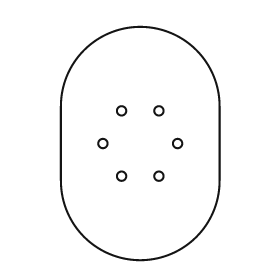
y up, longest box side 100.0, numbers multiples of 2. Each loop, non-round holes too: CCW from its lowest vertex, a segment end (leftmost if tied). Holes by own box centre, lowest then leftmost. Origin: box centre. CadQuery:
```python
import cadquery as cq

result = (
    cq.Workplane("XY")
    .moveTo(-34.0, -16.0)
    .threePointArc((0.0, -50.0), (34.0, -16.0))
    .lineTo(34.0, 16.0)
    .threePointArc((0.0, 50.0), (-34.0, 16.0))
    .close()
    .moveTo(-8.0, -14.0)
    .circle(2.0)
    .moveTo(8.0, -14.0)
    .circle(2.0)
    .moveTo(-16.0, 0.0)
    .circle(2.0)
    .moveTo(16.0, 0.0)
    .circle(2.0)
    .moveTo(-8.0, 14.0)
    .circle(2.0)
    .moveTo(8.0, 14.0)
    .circle(2.0)
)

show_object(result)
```